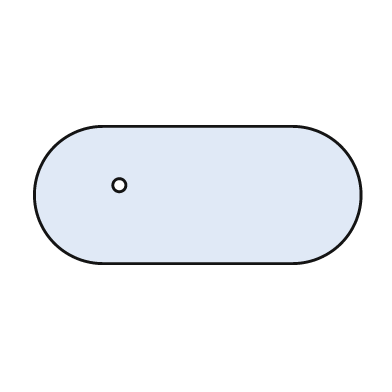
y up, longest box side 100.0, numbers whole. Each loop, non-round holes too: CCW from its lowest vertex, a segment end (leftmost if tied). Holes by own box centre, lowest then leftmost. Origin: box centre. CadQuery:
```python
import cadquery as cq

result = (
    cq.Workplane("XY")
    .moveTo(-29.0, -21.0)
    .lineTo(29.0, -21.0)
    .threePointArc((50.0, 0.0), (29.0, 21.0))
    .lineTo(-29.0, 21.0)
    .threePointArc((-50.0, 0.0), (-29.0, -21.0))
    .close()
    .moveTo(-24.0, 3.0)
    .circle(2.0)
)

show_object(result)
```